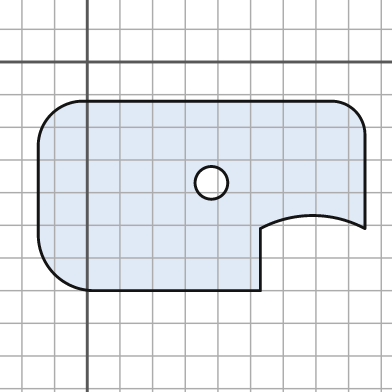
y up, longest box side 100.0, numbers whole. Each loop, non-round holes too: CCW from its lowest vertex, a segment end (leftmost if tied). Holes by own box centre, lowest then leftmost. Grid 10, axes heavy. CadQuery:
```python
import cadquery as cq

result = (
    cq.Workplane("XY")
    .moveTo(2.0, -70.0)
    .lineTo(53.0, -70.0)
    .lineTo(53.0, -51.0)
    .threePointArc((69.0, -47.0), (85.0, -51.0))
    .lineTo(85.0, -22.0)
    .threePointArc((82.0, -15.0), (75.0, -12.0))
    .lineTo(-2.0, -12.0)
    .threePointArc((-11.0, -16.0), (-15.0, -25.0))
    .lineTo(-15.0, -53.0)
    .threePointArc((-10.0, -65.0), (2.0, -70.0))
    .close()
    .moveTo(38.0, -37.0)
    .circle(5.0)
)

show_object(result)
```